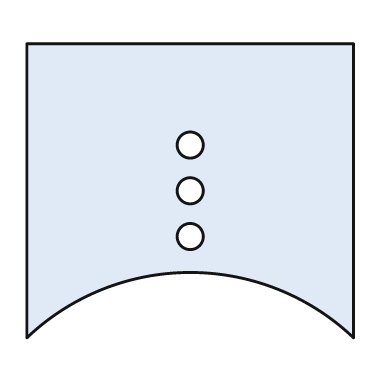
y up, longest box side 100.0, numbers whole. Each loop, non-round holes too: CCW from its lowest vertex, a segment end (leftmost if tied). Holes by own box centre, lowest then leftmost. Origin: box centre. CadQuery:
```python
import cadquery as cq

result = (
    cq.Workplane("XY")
    .moveTo(-50.0, -45.0)
    .threePointArc((0.0, -25.0), (50.0, -45.0))
    .lineTo(50.0, 45.0)
    .lineTo(-50.0, 45.0)
    .close()
    .moveTo(0.0, -14.0)
    .circle(4.0)
    .moveTo(0.0, 0.0)
    .circle(4.0)
    .moveTo(0.0, 14.0)
    .circle(4.0)
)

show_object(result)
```